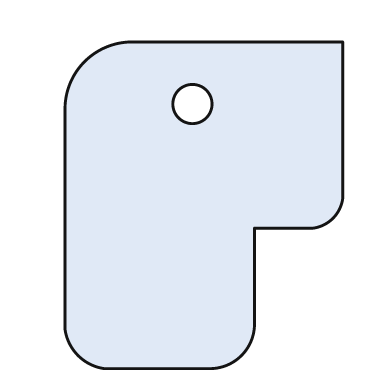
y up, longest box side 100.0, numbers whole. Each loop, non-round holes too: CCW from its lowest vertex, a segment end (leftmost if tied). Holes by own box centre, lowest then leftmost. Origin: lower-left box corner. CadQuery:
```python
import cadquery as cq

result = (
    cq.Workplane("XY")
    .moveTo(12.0, 0.0)
    .lineTo(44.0, 0.0)
    .threePointArc((54.0, 4.0), (58.0, 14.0))
    .lineTo(58.0, 43.0)
    .lineTo(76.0, 43.0)
    .threePointArc((82.0, 46.0), (85.0, 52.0))
    .lineTo(85.0, 100.0)
    .lineTo(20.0, 100.0)
    .threePointArc((6.0, 94.0), (0.0, 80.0))
    .lineTo(0.0, 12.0)
    .threePointArc((4.0, 4.0), (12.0, 0.0))
    .close()
    .moveTo(39.0, 81.0)
    .circle(6.0)
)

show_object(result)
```